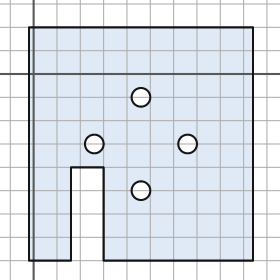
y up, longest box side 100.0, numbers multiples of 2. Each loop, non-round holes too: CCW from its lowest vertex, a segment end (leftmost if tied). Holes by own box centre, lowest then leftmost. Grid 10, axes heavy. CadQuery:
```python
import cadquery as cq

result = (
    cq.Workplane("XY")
    .moveTo(-2.0, -80.0)
    .lineTo(16.0, -80.0)
    .lineTo(16.0, -40.0)
    .lineTo(30.0, -40.0)
    .lineTo(30.0, -80.0)
    .lineTo(94.0, -80.0)
    .lineTo(94.0, 20.0)
    .lineTo(-2.0, 20.0)
    .close()
    .moveTo(46.0, -50.0)
    .circle(4.0)
    .moveTo(26.0, -30.0)
    .circle(4.0)
    .moveTo(66.0, -30.0)
    .circle(4.0)
    .moveTo(46.0, -10.0)
    .circle(4.0)
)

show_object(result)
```